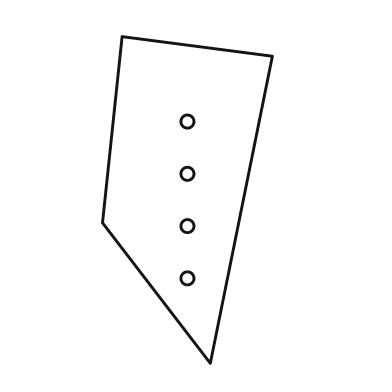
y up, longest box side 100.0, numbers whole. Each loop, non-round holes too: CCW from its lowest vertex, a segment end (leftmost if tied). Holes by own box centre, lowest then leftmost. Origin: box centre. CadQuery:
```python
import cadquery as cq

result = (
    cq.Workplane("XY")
    .moveTo(7.0, -50.0)
    .lineTo(26.0, 44.0)
    .lineTo(-20.0, 50.0)
    .lineTo(-26.0, -7.0)
    .close()
    .moveTo(0.0, -24.0)
    .circle(2.0)
    .moveTo(0.0, -8.0)
    .circle(2.0)
    .moveTo(0.0, 8.0)
    .circle(2.0)
    .moveTo(0.0, 24.0)
    .circle(2.0)
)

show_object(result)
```